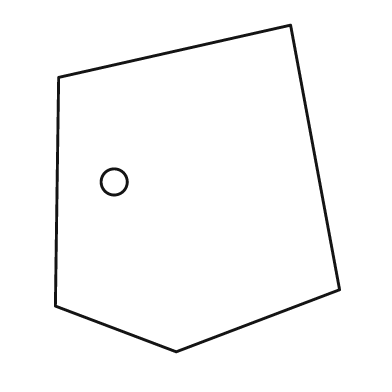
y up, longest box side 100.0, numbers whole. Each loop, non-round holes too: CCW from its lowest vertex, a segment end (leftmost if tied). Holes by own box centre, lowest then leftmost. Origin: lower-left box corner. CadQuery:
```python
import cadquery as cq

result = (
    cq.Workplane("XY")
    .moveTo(37.0, 0.0)
    .lineTo(87.0, 19.0)
    .lineTo(72.0, 100.0)
    .lineTo(1.0, 84.0)
    .lineTo(0.0, 14.0)
    .close()
    .moveTo(18.0, 52.0)
    .circle(4.0)
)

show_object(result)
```